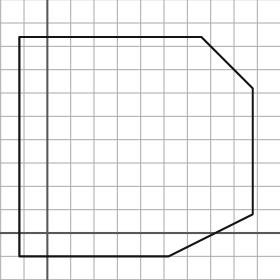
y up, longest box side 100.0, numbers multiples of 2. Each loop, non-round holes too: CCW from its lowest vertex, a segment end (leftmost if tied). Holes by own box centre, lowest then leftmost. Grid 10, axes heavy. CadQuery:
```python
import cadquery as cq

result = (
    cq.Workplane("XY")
    .moveTo(-12.0, -10.0)
    .lineTo(52.0, -10.0)
    .lineTo(88.0, 8.0)
    .lineTo(88.0, 62.0)
    .lineTo(66.0, 84.0)
    .lineTo(-12.0, 84.0)
    .close()
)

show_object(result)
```